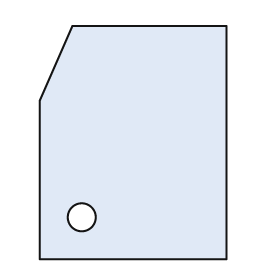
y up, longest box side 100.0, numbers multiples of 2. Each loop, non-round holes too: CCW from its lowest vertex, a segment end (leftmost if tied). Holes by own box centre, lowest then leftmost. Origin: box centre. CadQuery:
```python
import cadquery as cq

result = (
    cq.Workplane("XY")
    .moveTo(-40.0, -50.0)
    .lineTo(40.0, -50.0)
    .lineTo(40.0, 50.0)
    .lineTo(-26.0, 50.0)
    .lineTo(-40.0, 18.0)
    .close()
    .moveTo(-22.0, -32.0)
    .circle(6.0)
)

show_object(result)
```